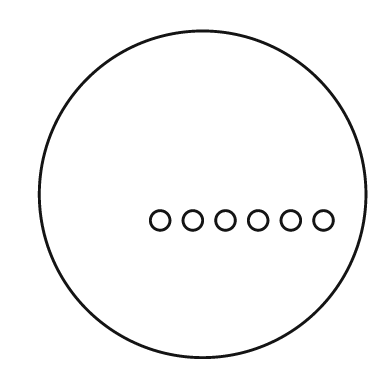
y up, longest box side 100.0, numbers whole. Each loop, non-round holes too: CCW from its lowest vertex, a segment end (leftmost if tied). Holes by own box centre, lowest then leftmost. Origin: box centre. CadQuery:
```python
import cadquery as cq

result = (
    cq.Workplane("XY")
    .moveTo(0.0, 0.0)
    .circle(50.0)
    .moveTo(-13.0, -8.0)
    .circle(3.0)
    .moveTo(-3.0, -8.0)
    .circle(3.0)
    .moveTo(7.0, -8.0)
    .circle(3.0)
    .moveTo(17.0, -8.0)
    .circle(3.0)
    .moveTo(27.0, -8.0)
    .circle(3.0)
    .moveTo(37.0, -8.0)
    .circle(3.0)
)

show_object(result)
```